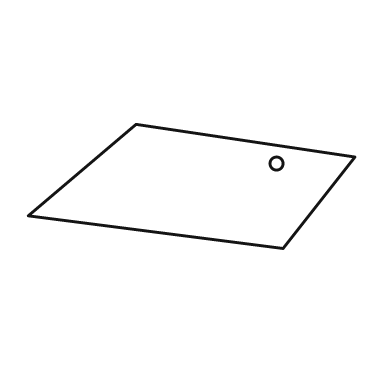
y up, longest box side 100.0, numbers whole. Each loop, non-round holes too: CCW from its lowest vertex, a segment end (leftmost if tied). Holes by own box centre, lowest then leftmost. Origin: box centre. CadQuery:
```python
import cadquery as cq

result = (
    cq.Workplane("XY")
    .moveTo(28.0, -19.0)
    .lineTo(50.0, 9.0)
    .lineTo(-17.0, 19.0)
    .lineTo(-50.0, -9.0)
    .close()
    .moveTo(26.0, 7.0)
    .circle(2.0)
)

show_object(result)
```